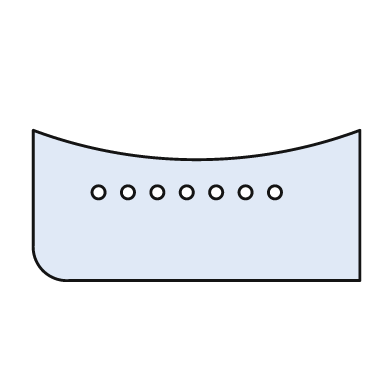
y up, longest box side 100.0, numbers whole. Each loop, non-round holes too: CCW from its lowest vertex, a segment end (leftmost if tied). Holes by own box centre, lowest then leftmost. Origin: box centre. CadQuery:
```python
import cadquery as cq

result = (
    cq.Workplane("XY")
    .moveTo(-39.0, -23.0)
    .lineTo(50.0, -23.0)
    .lineTo(50.0, 23.0)
    .threePointArc((0.0, 14.0), (-50.0, 23.0))
    .lineTo(-50.0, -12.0)
    .threePointArc((-47.0, -20.0), (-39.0, -23.0))
    .close()
    .moveTo(-30.0, 4.0)
    .circle(2.0)
    .moveTo(-21.0, 4.0)
    .circle(2.0)
    .moveTo(-12.0, 4.0)
    .circle(2.0)
    .moveTo(-3.0, 4.0)
    .circle(2.0)
    .moveTo(6.0, 4.0)
    .circle(2.0)
    .moveTo(15.0, 4.0)
    .circle(2.0)
    .moveTo(24.0, 4.0)
    .circle(2.0)
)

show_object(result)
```